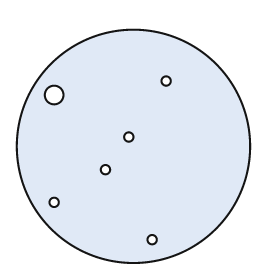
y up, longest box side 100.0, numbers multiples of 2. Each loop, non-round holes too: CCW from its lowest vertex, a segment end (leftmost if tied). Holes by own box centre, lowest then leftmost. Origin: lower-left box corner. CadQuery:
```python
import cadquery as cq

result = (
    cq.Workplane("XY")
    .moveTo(50.0, 50.0)
    .circle(50.0)
    .moveTo(58.0, 10.0)
    .circle(2.0)
    .moveTo(16.0, 26.0)
    .circle(2.0)
    .moveTo(38.0, 40.0)
    .circle(2.0)
    .moveTo(48.0, 54.0)
    .circle(2.0)
    .moveTo(16.0, 72.0)
    .circle(4.0)
    .moveTo(64.0, 78.0)
    .circle(2.0)
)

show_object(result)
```